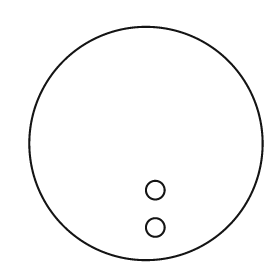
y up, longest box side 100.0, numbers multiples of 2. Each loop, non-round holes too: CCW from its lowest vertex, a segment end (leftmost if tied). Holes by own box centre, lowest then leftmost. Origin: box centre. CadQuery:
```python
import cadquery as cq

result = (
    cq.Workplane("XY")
    .moveTo(0.0, 0.0)
    .circle(50.0)
    .moveTo(4.0, -36.0)
    .circle(4.0)
    .moveTo(4.0, -20.0)
    .circle(4.0)
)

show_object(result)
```